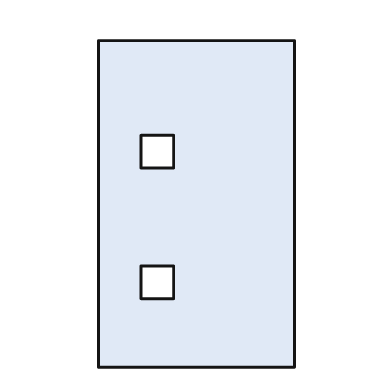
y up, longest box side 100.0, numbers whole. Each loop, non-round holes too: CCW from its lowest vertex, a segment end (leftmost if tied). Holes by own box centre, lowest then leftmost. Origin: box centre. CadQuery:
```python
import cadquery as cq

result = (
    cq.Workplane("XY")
    .moveTo(-30.0, -50.0)
    .lineTo(30.0, -50.0)
    .lineTo(30.0, 50.0)
    .lineTo(-30.0, 50.0)
    .close()
    .moveTo(-17.0, -29.0)
    .lineTo(-7.0, -29.0)
    .lineTo(-7.0, -19.0)
    .lineTo(-17.0, -19.0)
    .close()
    .moveTo(-17.0, 11.0)
    .lineTo(-7.0, 11.0)
    .lineTo(-7.0, 21.0)
    .lineTo(-17.0, 21.0)
    .close()
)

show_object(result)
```